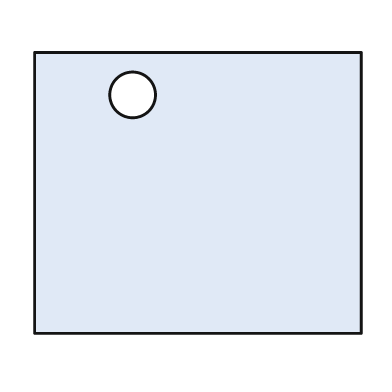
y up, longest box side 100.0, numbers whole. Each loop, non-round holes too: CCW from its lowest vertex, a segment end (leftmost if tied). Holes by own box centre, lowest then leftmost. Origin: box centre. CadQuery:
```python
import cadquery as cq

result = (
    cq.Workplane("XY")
    .moveTo(-50.0, -43.0)
    .lineTo(50.0, -43.0)
    .lineTo(50.0, 43.0)
    .lineTo(-50.0, 43.0)
    .close()
    .moveTo(-20.0, 30.0)
    .circle(7.0)
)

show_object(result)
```